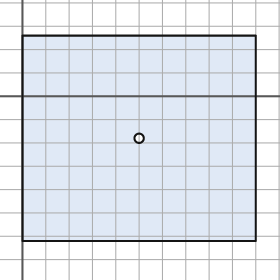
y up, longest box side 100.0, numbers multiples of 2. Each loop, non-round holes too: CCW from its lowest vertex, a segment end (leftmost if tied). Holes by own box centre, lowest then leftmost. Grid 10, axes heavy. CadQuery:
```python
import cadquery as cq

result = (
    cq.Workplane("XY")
    .moveTo(0.0, -62.0)
    .lineTo(100.0, -62.0)
    .lineTo(100.0, 26.0)
    .lineTo(0.0, 26.0)
    .close()
    .moveTo(50.0, -18.0)
    .circle(2.0)
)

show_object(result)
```